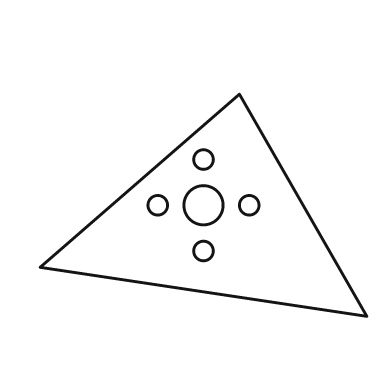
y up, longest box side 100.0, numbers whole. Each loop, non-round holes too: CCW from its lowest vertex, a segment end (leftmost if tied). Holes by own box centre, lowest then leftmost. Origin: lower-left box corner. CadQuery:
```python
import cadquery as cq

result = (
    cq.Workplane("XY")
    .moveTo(100.0, 0.0)
    .lineTo(61.0, 68.0)
    .lineTo(0.0, 15.0)
    .close()
    .moveTo(50.0, 20.0)
    .circle(3.0)
    .moveTo(36.0, 34.0)
    .circle(3.0)
    .moveTo(50.0, 34.0)
    .circle(6.0)
    .moveTo(64.0, 34.0)
    .circle(3.0)
    .moveTo(50.0, 48.0)
    .circle(3.0)
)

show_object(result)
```